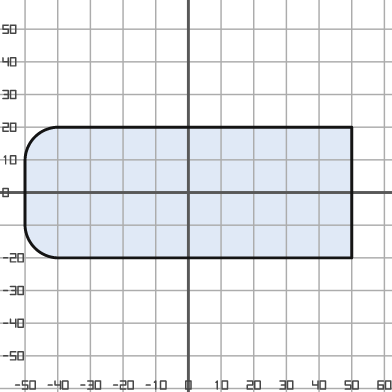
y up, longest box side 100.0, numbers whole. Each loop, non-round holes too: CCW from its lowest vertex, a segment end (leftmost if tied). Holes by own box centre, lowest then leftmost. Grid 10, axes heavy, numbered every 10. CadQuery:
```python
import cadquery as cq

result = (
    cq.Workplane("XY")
    .moveTo(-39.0, -20.0)
    .lineTo(50.0, -20.0)
    .lineTo(50.0, 20.0)
    .lineTo(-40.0, 20.0)
    .threePointArc((-47.0, 17.0), (-50.0, 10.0))
    .lineTo(-50.0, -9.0)
    .threePointArc((-47.0, -17.0), (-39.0, -20.0))
    .close()
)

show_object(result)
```